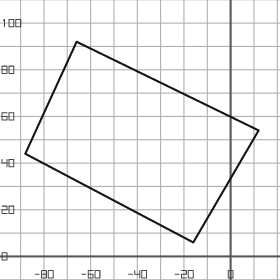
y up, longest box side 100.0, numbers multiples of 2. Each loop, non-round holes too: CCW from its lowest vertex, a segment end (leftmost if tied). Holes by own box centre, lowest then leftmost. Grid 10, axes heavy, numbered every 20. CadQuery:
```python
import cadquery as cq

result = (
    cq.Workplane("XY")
    .moveTo(-16.0, 6.0)
    .lineTo(12.0, 54.0)
    .lineTo(-66.0, 92.0)
    .lineTo(-88.0, 44.0)
    .close()
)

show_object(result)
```